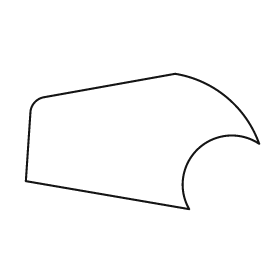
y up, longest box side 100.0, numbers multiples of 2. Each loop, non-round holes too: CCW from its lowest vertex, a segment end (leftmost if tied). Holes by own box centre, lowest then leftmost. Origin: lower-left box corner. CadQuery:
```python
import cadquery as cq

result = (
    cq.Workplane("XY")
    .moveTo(70.0, 0.0)
    .threePointArc((74.0, 26.0), (100.0, 28.0))
    .threePointArc((86.0, 48.0), (64.0, 58.0))
    .lineTo(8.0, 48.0)
    .threePointArc((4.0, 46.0), (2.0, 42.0))
    .lineTo(0.0, 12.0)
    .close()
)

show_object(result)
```